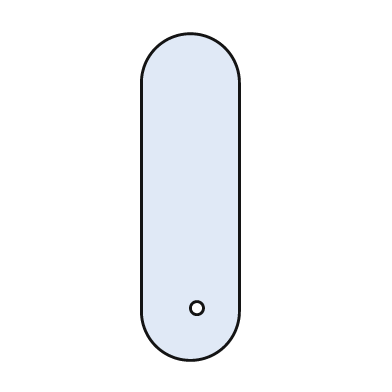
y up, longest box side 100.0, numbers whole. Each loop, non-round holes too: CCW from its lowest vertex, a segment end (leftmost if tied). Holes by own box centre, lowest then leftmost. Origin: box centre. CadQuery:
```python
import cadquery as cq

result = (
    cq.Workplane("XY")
    .moveTo(-15.0, -35.0)
    .threePointArc((0.0, -50.0), (15.0, -35.0))
    .lineTo(15.0, 35.0)
    .threePointArc((0.0, 50.0), (-15.0, 35.0))
    .close()
    .moveTo(2.0, -34.0)
    .circle(2.0)
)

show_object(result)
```